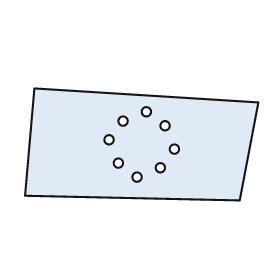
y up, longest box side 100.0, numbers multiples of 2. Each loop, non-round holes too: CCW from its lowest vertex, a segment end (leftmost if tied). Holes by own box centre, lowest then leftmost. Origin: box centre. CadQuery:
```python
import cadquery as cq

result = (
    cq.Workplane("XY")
    .moveTo(42.0, -24.0)
    .lineTo(50.0, 18.0)
    .lineTo(-46.0, 24.0)
    .lineTo(-50.0, -22.0)
    .close()
    .moveTo(-2.0, -14.0)
    .circle(2.0)
    .moveTo(8.0, -10.0)
    .circle(2.0)
    .moveTo(-10.0, -8.0)
    .circle(2.0)
    .moveTo(14.0, -2.0)
    .circle(2.0)
    .moveTo(-14.0, 2.0)
    .circle(2.0)
    .moveTo(10.0, 8.0)
    .circle(2.0)
    .moveTo(-8.0, 10.0)
    .circle(2.0)
    .moveTo(2.0, 14.0)
    .circle(2.0)
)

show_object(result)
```